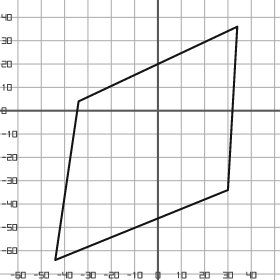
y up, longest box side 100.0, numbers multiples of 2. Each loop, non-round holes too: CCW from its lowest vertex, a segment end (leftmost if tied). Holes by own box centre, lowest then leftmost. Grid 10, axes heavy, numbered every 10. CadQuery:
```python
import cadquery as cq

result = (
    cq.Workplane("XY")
    .moveTo(-44.0, -64.0)
    .lineTo(30.0, -34.0)
    .lineTo(34.0, 36.0)
    .lineTo(-34.0, 4.0)
    .close()
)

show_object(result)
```